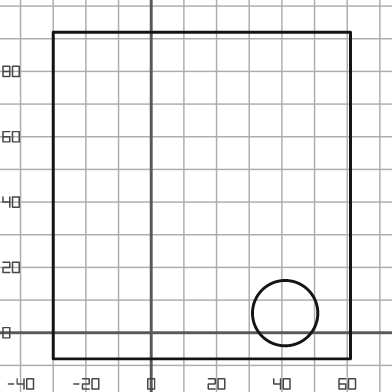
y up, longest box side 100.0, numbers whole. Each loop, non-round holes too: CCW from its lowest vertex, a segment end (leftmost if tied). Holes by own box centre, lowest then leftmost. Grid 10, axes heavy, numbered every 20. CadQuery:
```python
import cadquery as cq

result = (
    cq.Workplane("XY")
    .moveTo(-30.0, -8.0)
    .lineTo(61.0, -8.0)
    .lineTo(61.0, 92.0)
    .lineTo(-30.0, 92.0)
    .close()
    .moveTo(41.0, 6.0)
    .circle(10.0)
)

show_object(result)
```